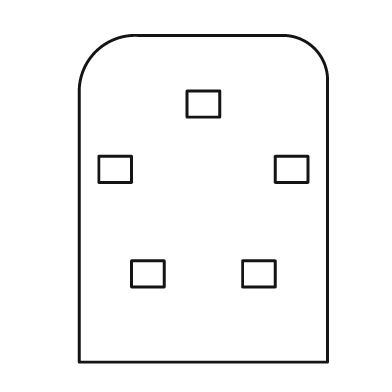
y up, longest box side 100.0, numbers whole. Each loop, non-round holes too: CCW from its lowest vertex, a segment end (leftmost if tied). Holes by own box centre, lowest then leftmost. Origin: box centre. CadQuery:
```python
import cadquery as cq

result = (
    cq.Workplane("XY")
    .moveTo(-38.0, -50.0)
    .lineTo(38.0, -50.0)
    .lineTo(38.0, 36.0)
    .threePointArc((34.0, 46.0), (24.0, 50.0))
    .lineTo(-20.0, 50.0)
    .threePointArc((-33.0, 45.0), (-38.0, 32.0))
    .close()
    .moveTo(-22.0, -27.0)
    .lineTo(-12.0, -27.0)
    .lineTo(-12.0, -19.0)
    .lineTo(-22.0, -19.0)
    .close()
    .moveTo(12.0, -27.0)
    .lineTo(22.0, -27.0)
    .lineTo(22.0, -19.0)
    .lineTo(12.0, -19.0)
    .close()
    .moveTo(-32.0, 5.0)
    .lineTo(-22.0, 5.0)
    .lineTo(-22.0, 13.0)
    .lineTo(-32.0, 13.0)
    .close()
    .moveTo(22.0, 5.0)
    .lineTo(32.0, 5.0)
    .lineTo(32.0, 13.0)
    .lineTo(22.0, 13.0)
    .close()
    .moveTo(-5.0, 25.0)
    .lineTo(5.0, 25.0)
    .lineTo(5.0, 33.0)
    .lineTo(-5.0, 33.0)
    .close()
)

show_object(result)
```